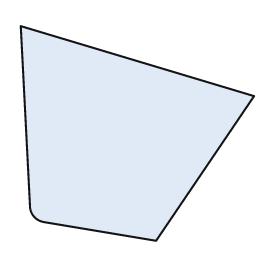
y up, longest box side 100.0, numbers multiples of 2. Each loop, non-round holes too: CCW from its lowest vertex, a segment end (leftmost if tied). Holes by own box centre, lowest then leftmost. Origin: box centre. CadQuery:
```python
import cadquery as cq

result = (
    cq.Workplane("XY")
    .moveTo(8.0, -46.0)
    .lineTo(50.0, 16.0)
    .lineTo(-50.0, 46.0)
    .lineTo(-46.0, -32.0)
    .threePointArc((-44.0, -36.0), (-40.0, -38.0))
    .close()
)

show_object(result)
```